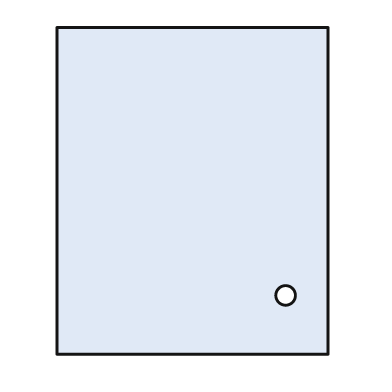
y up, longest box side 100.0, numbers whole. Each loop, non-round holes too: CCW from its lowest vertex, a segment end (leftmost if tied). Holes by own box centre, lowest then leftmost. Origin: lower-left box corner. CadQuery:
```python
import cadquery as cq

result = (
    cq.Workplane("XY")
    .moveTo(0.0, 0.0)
    .lineTo(83.0, 0.0)
    .lineTo(83.0, 100.0)
    .lineTo(0.0, 100.0)
    .close()
    .moveTo(70.0, 18.0)
    .circle(3.0)
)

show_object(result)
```